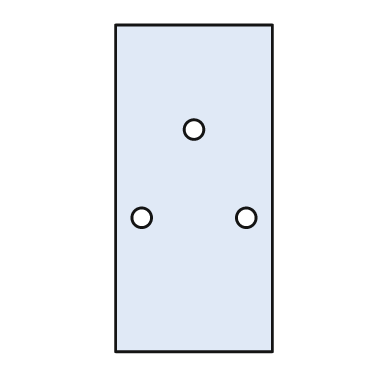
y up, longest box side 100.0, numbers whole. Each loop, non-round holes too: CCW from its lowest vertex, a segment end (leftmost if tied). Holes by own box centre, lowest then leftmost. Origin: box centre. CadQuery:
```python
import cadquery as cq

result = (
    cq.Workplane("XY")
    .moveTo(-24.0, -50.0)
    .lineTo(24.0, -50.0)
    .lineTo(24.0, 50.0)
    .lineTo(-24.0, 50.0)
    .close()
    .moveTo(-16.0, -9.0)
    .circle(3.0)
    .moveTo(16.0, -9.0)
    .circle(3.0)
    .moveTo(0.0, 18.0)
    .circle(3.0)
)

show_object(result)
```